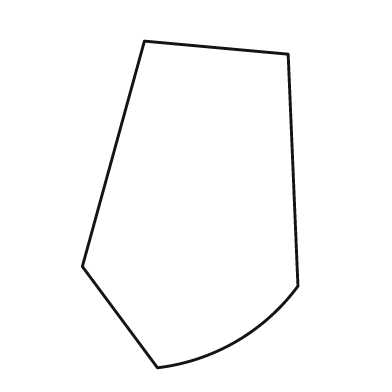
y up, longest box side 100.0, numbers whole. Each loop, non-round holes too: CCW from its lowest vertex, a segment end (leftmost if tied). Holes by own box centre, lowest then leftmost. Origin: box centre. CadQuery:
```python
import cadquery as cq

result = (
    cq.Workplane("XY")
    .moveTo(-10.0, -50.0)
    .threePointArc((14.0, -42.0), (33.0, -25.0))
    .lineTo(30.0, 46.0)
    .lineTo(-14.0, 50.0)
    .lineTo(-33.0, -19.0)
    .close()
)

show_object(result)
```